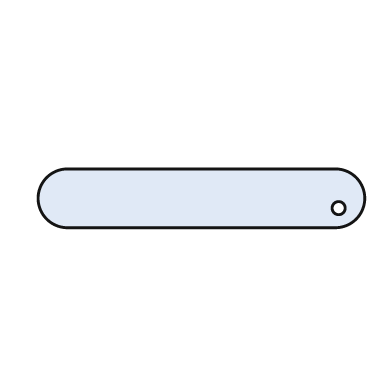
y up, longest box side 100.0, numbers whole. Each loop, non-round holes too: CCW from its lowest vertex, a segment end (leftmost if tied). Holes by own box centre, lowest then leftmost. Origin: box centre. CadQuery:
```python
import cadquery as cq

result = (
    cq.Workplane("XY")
    .moveTo(-41.0, -9.0)
    .lineTo(41.0, -9.0)
    .threePointArc((50.0, 0.0), (41.0, 9.0))
    .lineTo(-41.0, 9.0)
    .threePointArc((-50.0, 0.0), (-41.0, -9.0))
    .close()
    .moveTo(42.0, -3.0)
    .circle(2.0)
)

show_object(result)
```